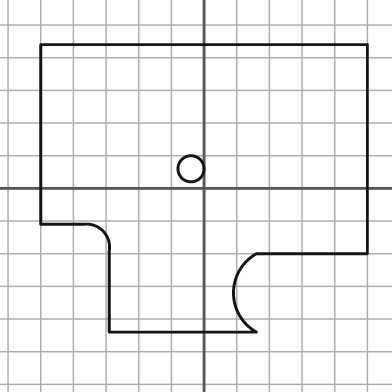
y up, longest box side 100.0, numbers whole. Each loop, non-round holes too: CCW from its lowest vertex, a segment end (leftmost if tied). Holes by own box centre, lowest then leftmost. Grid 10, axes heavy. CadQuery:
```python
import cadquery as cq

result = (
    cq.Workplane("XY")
    .moveTo(-29.0, -44.0)
    .lineTo(16.0, -44.0)
    .threePointArc((9.0, -32.0), (16.0, -20.0))
    .lineTo(50.0, -20.0)
    .lineTo(50.0, 44.0)
    .lineTo(-50.0, 44.0)
    .lineTo(-50.0, -11.0)
    .lineTo(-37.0, -11.0)
    .threePointArc((-31.0, -13.0), (-29.0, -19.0))
    .close()
    .moveTo(-4.0, 6.0)
    .circle(4.0)
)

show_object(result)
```